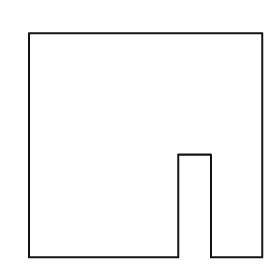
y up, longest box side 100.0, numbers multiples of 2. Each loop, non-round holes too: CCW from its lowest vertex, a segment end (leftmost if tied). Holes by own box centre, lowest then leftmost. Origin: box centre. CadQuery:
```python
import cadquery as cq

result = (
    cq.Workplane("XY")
    .moveTo(-50.0, -48.0)
    .lineTo(14.0, -48.0)
    .lineTo(14.0, -4.0)
    .lineTo(28.0, -4.0)
    .lineTo(28.0, -48.0)
    .lineTo(50.0, -48.0)
    .lineTo(50.0, 48.0)
    .lineTo(-50.0, 48.0)
    .close()
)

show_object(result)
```